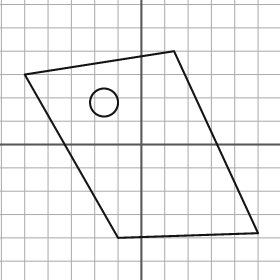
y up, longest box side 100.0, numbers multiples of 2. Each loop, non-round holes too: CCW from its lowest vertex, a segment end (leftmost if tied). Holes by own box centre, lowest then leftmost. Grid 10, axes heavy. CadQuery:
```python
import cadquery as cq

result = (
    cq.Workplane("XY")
    .moveTo(-10.0, -40.0)
    .lineTo(50.0, -38.0)
    .lineTo(14.0, 40.0)
    .lineTo(-50.0, 30.0)
    .close()
    .moveTo(-16.0, 18.0)
    .circle(6.0)
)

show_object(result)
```